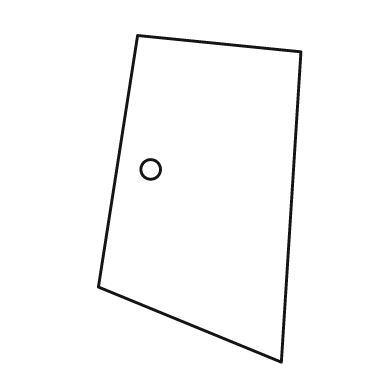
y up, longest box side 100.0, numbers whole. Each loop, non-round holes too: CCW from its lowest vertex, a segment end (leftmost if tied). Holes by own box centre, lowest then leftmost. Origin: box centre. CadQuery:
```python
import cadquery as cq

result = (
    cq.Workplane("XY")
    .moveTo(25.0, -50.0)
    .lineTo(31.0, 45.0)
    .lineTo(-19.0, 50.0)
    .lineTo(-31.0, -27.0)
    .close()
    .moveTo(-15.0, 9.0)
    .circle(3.0)
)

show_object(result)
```